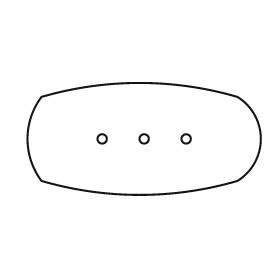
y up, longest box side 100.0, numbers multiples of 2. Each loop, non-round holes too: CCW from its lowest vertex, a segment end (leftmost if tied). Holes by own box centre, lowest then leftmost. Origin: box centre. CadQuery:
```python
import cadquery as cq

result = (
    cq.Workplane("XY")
    .moveTo(-44.0, -18.0)
    .threePointArc((-2.0, -24.0), (40.0, -18.0))
    .threePointArc((50.0, 0.0), (40.0, 18.0))
    .threePointArc((-2.0, 24.0), (-44.0, 18.0))
    .threePointArc((-50.0, 0.0), (-44.0, -18.0))
    .close()
    .moveTo(-18.0, 0.0)
    .circle(2.0)
    .moveTo(0.0, 0.0)
    .circle(2.0)
    .moveTo(18.0, 0.0)
    .circle(2.0)
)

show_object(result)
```